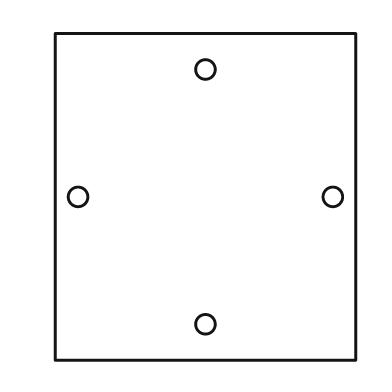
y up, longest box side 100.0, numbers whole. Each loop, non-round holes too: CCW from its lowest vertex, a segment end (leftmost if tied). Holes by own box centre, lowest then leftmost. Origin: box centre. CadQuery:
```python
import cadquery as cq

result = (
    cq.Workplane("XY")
    .moveTo(-46.0, -50.0)
    .lineTo(46.0, -50.0)
    .lineTo(46.0, 50.0)
    .lineTo(-46.0, 50.0)
    .close()
    .moveTo(0.0, -39.0)
    .circle(3.0)
    .moveTo(-39.0, 0.0)
    .circle(3.0)
    .moveTo(39.0, 0.0)
    .circle(3.0)
    .moveTo(0.0, 39.0)
    .circle(3.0)
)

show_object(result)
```